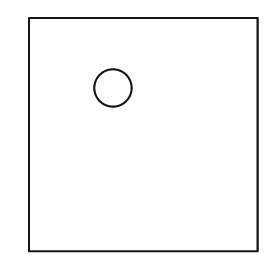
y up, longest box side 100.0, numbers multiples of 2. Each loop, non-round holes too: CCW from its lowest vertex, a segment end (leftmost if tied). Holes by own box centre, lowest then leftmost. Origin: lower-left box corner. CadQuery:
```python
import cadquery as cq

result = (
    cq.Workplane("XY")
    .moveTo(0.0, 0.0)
    .lineTo(98.0, 0.0)
    .lineTo(98.0, 100.0)
    .lineTo(0.0, 100.0)
    .close()
    .moveTo(36.0, 70.0)
    .circle(8.0)
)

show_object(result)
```